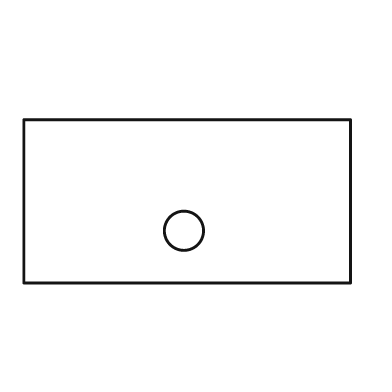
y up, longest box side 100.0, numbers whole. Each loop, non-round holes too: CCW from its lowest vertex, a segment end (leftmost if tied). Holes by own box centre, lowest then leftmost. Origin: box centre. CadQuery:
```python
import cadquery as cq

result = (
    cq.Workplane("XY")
    .moveTo(-50.0, -25.0)
    .lineTo(50.0, -25.0)
    .lineTo(50.0, 25.0)
    .lineTo(-50.0, 25.0)
    .close()
    .moveTo(-1.0, -9.0)
    .circle(6.0)
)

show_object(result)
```